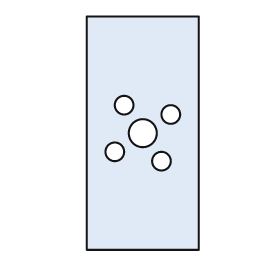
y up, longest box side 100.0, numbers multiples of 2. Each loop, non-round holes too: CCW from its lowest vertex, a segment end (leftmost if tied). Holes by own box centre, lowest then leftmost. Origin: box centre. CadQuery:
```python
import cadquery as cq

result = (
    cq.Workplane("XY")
    .moveTo(-24.0, -50.0)
    .lineTo(24.0, -50.0)
    .lineTo(24.0, 50.0)
    .lineTo(-24.0, 50.0)
    .close()
    .moveTo(8.0, -12.0)
    .circle(4.0)
    .moveTo(-12.0, -8.0)
    .circle(4.0)
    .moveTo(0.0, 0.0)
    .circle(6.0)
    .moveTo(12.0, 8.0)
    .circle(4.0)
    .moveTo(-8.0, 12.0)
    .circle(4.0)
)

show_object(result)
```